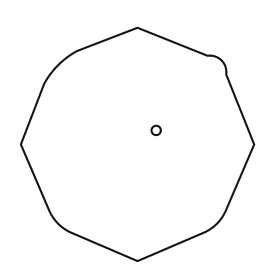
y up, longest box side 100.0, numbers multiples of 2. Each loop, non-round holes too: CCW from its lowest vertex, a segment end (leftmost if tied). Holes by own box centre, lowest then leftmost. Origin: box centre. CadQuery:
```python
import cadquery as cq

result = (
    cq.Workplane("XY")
    .moveTo(0.0, -50.0)
    .lineTo(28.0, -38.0)
    .threePointArc((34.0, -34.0), (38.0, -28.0))
    .lineTo(50.0, 0.0)
    .lineTo(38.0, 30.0)
    .threePointArc((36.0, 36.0), (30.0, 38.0))
    .lineTo(0.0, 50.0)
    .lineTo(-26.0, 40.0)
    .threePointArc((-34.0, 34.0), (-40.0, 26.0))
    .lineTo(-50.0, 0.0)
    .lineTo(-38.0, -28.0)
    .threePointArc((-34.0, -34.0), (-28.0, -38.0))
    .close()
    .moveTo(8.0, 6.0)
    .circle(2.0)
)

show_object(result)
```